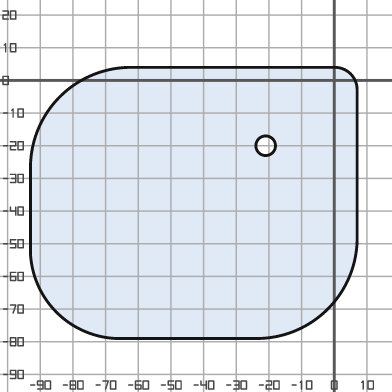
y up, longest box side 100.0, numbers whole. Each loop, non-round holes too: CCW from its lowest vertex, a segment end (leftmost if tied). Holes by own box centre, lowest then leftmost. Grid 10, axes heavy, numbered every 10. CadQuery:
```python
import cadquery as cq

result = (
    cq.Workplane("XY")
    .moveTo(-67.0, -79.0)
    .lineTo(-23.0, -79.0)
    .threePointArc((-2.0, -70.0), (7.0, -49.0))
    .lineTo(7.0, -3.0)
    .threePointArc((5.0, 2.0), (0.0, 4.0))
    .lineTo(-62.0, 4.0)
    .threePointArc((-84.0, -5.0), (-93.0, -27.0))
    .lineTo(-93.0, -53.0)
    .threePointArc((-85.0, -71.0), (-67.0, -79.0))
    .close()
    .moveTo(-21.0, -20.0)
    .circle(3.0)
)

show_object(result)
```